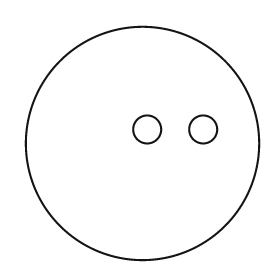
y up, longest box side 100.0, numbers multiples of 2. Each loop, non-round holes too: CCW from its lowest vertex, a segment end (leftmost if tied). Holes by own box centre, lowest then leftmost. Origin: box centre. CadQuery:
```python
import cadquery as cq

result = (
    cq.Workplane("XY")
    .moveTo(0.0, 0.0)
    .circle(50.0)
    .moveTo(2.0, 6.0)
    .circle(6.0)
    .moveTo(26.0, 6.0)
    .circle(6.0)
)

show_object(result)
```